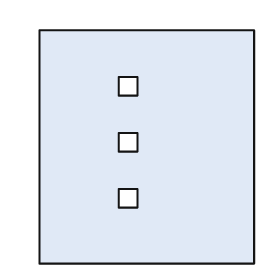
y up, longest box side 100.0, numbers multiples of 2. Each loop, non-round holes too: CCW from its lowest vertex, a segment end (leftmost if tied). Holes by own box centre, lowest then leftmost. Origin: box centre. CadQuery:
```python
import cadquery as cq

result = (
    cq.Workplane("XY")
    .moveTo(-46.0, -50.0)
    .lineTo(46.0, -50.0)
    .lineTo(46.0, 50.0)
    .lineTo(-46.0, 50.0)
    .close()
    .moveTo(-12.0, -26.0)
    .lineTo(-4.0, -26.0)
    .lineTo(-4.0, -18.0)
    .lineTo(-12.0, -18.0)
    .close()
    .moveTo(-12.0, -2.0)
    .lineTo(-4.0, -2.0)
    .lineTo(-4.0, 6.0)
    .lineTo(-12.0, 6.0)
    .close()
    .moveTo(-12.0, 22.0)
    .lineTo(-4.0, 22.0)
    .lineTo(-4.0, 30.0)
    .lineTo(-12.0, 30.0)
    .close()
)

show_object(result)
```